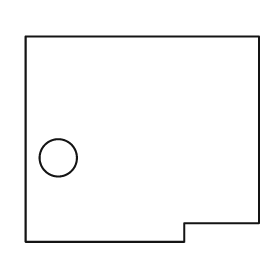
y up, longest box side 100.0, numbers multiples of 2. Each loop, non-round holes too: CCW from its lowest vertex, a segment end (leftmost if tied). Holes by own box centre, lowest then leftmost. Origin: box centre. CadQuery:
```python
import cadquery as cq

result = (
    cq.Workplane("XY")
    .moveTo(-50.0, -44.0)
    .lineTo(18.0, -44.0)
    .lineTo(18.0, -36.0)
    .lineTo(50.0, -36.0)
    .lineTo(50.0, 44.0)
    .lineTo(-50.0, 44.0)
    .close()
    .moveTo(-36.0, -8.0)
    .circle(8.0)
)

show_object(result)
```